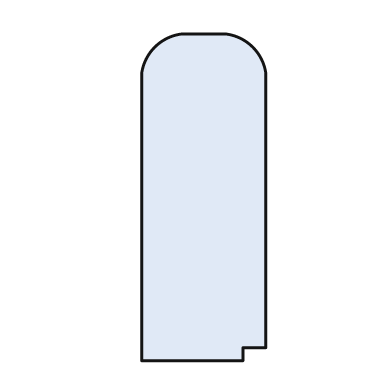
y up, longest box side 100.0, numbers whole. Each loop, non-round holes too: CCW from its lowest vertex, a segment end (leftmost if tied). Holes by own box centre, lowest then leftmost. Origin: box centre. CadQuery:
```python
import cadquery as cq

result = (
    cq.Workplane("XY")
    .moveTo(-19.0, -50.0)
    .lineTo(12.0, -50.0)
    .lineTo(12.0, -46.0)
    .lineTo(19.0, -46.0)
    .lineTo(19.0, 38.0)
    .threePointArc((15.0, 46.0), (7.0, 50.0))
    .lineTo(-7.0, 50.0)
    .threePointArc((-15.0, 46.0), (-19.0, 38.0))
    .close()
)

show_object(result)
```